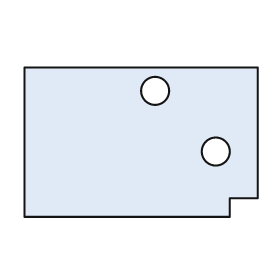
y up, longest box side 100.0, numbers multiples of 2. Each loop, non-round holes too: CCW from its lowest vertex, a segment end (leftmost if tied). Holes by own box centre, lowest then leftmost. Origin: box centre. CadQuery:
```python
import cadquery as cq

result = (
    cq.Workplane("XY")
    .moveTo(-50.0, -32.0)
    .lineTo(38.0, -32.0)
    .lineTo(38.0, -24.0)
    .lineTo(50.0, -24.0)
    .lineTo(50.0, 32.0)
    .lineTo(-50.0, 32.0)
    .close()
    .moveTo(32.0, -4.0)
    .circle(6.0)
    .moveTo(6.0, 22.0)
    .circle(6.0)
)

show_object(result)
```